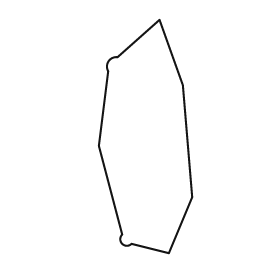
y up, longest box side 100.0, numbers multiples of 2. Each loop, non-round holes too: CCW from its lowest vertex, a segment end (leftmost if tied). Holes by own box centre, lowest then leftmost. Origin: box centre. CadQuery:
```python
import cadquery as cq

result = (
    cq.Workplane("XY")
    .moveTo(10.0, -50.0)
    .lineTo(20.0, -26.0)
    .lineTo(16.0, 22.0)
    .lineTo(6.0, 50.0)
    .lineTo(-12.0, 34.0)
    .threePointArc((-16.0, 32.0), (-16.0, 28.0))
    .lineTo(-20.0, -4.0)
    .lineTo(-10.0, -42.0)
    .threePointArc((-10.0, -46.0), (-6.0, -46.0))
    .close()
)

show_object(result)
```